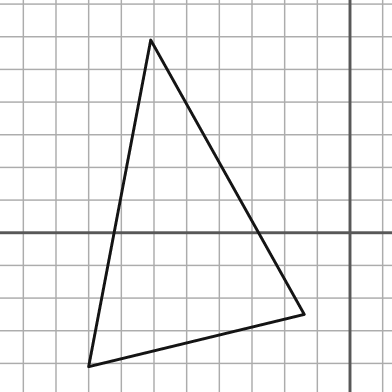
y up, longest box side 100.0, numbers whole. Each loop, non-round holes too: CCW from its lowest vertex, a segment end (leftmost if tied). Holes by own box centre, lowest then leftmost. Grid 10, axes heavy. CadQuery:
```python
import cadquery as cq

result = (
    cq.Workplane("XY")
    .moveTo(-80.0, -41.0)
    .lineTo(-14.0, -25.0)
    .lineTo(-61.0, 59.0)
    .close()
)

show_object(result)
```